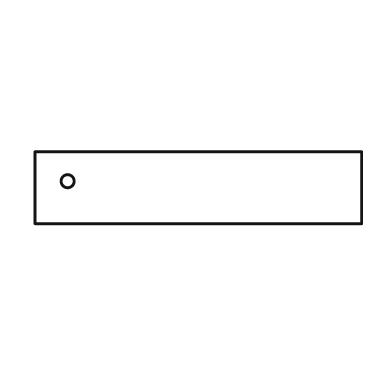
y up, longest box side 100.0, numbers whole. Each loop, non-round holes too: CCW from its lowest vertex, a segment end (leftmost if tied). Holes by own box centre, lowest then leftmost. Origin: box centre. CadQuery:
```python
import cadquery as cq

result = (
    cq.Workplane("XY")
    .moveTo(-50.0, -11.0)
    .lineTo(50.0, -11.0)
    .lineTo(50.0, 11.0)
    .lineTo(-50.0, 11.0)
    .close()
    .moveTo(-40.0, 2.0)
    .circle(2.0)
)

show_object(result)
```